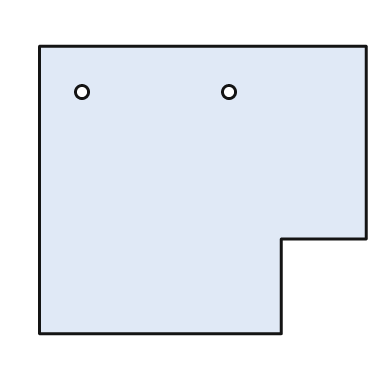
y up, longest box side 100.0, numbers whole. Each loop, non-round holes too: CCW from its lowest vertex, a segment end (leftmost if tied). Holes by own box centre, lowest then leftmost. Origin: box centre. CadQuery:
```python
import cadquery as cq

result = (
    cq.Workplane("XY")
    .moveTo(-50.0, -44.0)
    .lineTo(24.0, -44.0)
    .lineTo(24.0, -15.0)
    .lineTo(50.0, -15.0)
    .lineTo(50.0, 44.0)
    .lineTo(-50.0, 44.0)
    .close()
    .moveTo(-37.0, 30.0)
    .circle(2.0)
    .moveTo(8.0, 30.0)
    .circle(2.0)
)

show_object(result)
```